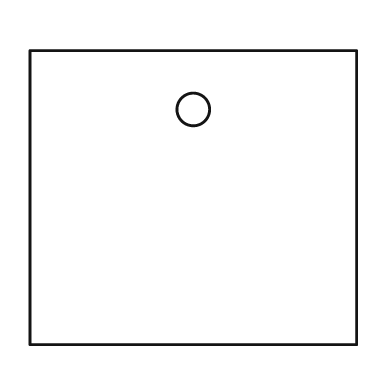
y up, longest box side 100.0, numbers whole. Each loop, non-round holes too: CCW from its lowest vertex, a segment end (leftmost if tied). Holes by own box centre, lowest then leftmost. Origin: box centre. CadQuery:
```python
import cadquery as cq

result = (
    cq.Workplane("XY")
    .moveTo(-50.0, -45.0)
    .lineTo(50.0, -45.0)
    .lineTo(50.0, 45.0)
    .lineTo(-50.0, 45.0)
    .close()
    .moveTo(0.0, 27.0)
    .circle(5.0)
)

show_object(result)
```